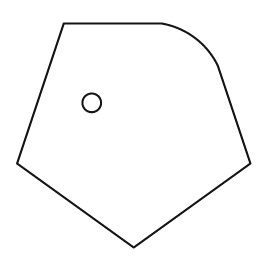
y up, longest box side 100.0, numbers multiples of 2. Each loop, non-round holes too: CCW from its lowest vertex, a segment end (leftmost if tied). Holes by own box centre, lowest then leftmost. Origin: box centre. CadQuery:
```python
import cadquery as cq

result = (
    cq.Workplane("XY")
    .moveTo(0.0, -48.0)
    .lineTo(50.0, -12.0)
    .lineTo(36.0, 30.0)
    .threePointArc((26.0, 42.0), (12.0, 48.0))
    .lineTo(-30.0, 48.0)
    .lineTo(-50.0, -12.0)
    .close()
    .moveTo(-18.0, 14.0)
    .circle(4.0)
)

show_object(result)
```